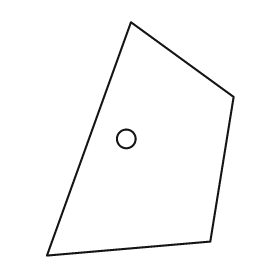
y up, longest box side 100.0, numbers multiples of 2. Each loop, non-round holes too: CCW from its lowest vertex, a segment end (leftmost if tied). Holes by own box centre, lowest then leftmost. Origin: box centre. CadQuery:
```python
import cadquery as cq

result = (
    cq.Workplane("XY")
    .moveTo(-40.0, -50.0)
    .lineTo(30.0, -44.0)
    .lineTo(40.0, 18.0)
    .lineTo(-4.0, 50.0)
    .close()
    .moveTo(-6.0, 0.0)
    .circle(4.0)
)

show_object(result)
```